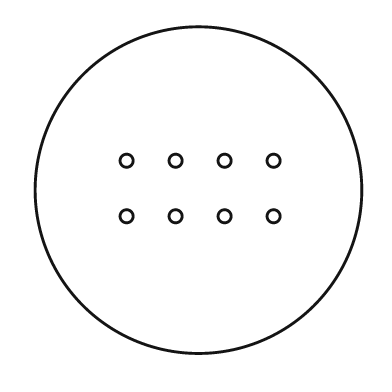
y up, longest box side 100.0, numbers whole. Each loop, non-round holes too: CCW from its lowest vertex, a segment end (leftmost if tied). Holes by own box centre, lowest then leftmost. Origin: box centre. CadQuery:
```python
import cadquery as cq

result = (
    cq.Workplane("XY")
    .moveTo(0.0, 0.0)
    .circle(50.0)
    .moveTo(-22.0, -8.0)
    .circle(2.0)
    .moveTo(-7.0, -8.0)
    .circle(2.0)
    .moveTo(8.0, -8.0)
    .circle(2.0)
    .moveTo(23.0, -8.0)
    .circle(2.0)
    .moveTo(-22.0, 9.0)
    .circle(2.0)
    .moveTo(-7.0, 9.0)
    .circle(2.0)
    .moveTo(8.0, 9.0)
    .circle(2.0)
    .moveTo(23.0, 9.0)
    .circle(2.0)
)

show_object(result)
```